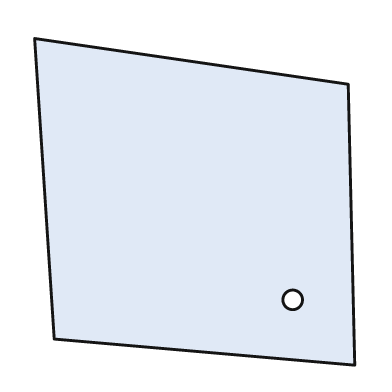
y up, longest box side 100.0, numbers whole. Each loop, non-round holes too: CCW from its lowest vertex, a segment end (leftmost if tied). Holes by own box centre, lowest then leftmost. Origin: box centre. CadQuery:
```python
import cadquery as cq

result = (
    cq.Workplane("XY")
    .moveTo(49.0, -50.0)
    .lineTo(47.0, 36.0)
    .lineTo(-49.0, 50.0)
    .lineTo(-43.0, -42.0)
    .close()
    .moveTo(30.0, -30.0)
    .circle(3.0)
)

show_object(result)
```